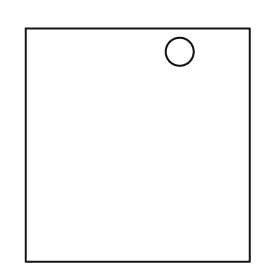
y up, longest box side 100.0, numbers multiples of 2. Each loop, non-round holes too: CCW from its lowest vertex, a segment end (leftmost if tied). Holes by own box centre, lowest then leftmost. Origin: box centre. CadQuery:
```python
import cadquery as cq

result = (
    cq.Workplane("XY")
    .moveTo(-48.0, -50.0)
    .lineTo(48.0, -50.0)
    .lineTo(48.0, 50.0)
    .lineTo(-48.0, 50.0)
    .close()
    .moveTo(18.0, 40.0)
    .circle(6.0)
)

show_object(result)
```